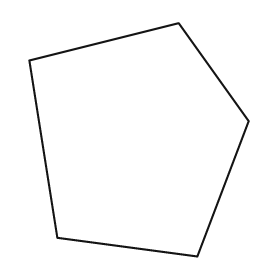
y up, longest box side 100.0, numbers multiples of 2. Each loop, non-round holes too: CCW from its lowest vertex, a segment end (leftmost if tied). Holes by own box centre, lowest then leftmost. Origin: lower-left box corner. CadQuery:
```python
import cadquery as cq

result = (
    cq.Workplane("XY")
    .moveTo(72.0, 0.0)
    .lineTo(94.0, 58.0)
    .lineTo(64.0, 100.0)
    .lineTo(0.0, 84.0)
    .lineTo(12.0, 8.0)
    .close()
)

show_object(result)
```